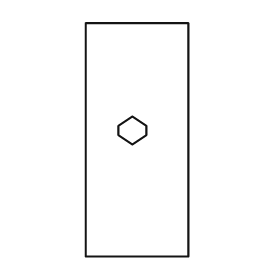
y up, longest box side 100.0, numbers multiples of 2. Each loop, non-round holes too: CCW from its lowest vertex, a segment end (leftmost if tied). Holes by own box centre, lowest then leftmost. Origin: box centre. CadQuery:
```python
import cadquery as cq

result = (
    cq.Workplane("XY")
    .moveTo(-22.0, -50.0)
    .lineTo(22.0, -50.0)
    .lineTo(22.0, 50.0)
    .lineTo(-22.0, 50.0)
    .close()
    .moveTo(-2.0, -2.0)
    .lineTo(4.0, 2.0)
    .lineTo(4.0, 6.0)
    .lineTo(-2.0, 10.0)
    .lineTo(-8.0, 6.0)
    .lineTo(-8.0, 2.0)
    .close()
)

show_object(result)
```